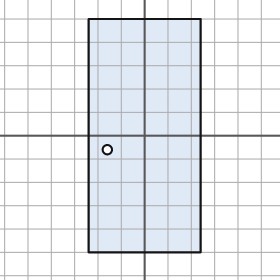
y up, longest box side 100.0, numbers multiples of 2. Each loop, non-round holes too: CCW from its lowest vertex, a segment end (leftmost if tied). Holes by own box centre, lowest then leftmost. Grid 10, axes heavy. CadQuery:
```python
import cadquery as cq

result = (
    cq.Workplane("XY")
    .moveTo(-24.0, -50.0)
    .lineTo(24.0, -50.0)
    .lineTo(24.0, 50.0)
    .lineTo(-24.0, 50.0)
    .close()
    .moveTo(-16.0, -6.0)
    .circle(2.0)
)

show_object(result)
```